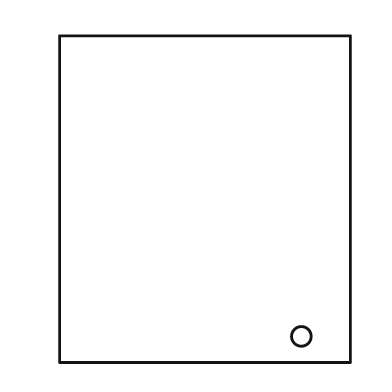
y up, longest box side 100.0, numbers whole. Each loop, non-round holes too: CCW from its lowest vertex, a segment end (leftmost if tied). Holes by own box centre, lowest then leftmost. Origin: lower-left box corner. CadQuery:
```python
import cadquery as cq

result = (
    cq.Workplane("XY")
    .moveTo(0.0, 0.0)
    .lineTo(89.0, 0.0)
    .lineTo(89.0, 100.0)
    .lineTo(0.0, 100.0)
    .close()
    .moveTo(74.0, 8.0)
    .circle(3.0)
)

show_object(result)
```